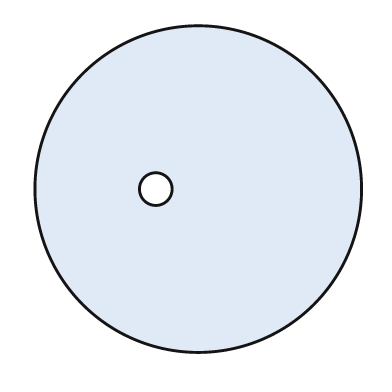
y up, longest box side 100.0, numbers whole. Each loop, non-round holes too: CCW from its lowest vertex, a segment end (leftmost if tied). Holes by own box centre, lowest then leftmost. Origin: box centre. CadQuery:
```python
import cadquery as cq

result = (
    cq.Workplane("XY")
    .moveTo(0.0, 0.0)
    .circle(50.0)
    .moveTo(-13.0, 0.0)
    .circle(5.0)
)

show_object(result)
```